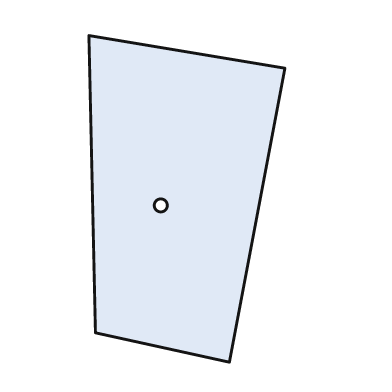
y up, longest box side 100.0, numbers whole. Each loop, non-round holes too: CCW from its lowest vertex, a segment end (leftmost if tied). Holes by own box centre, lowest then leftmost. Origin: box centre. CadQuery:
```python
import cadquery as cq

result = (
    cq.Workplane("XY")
    .moveTo(13.0, -50.0)
    .lineTo(30.0, 40.0)
    .lineTo(-30.0, 50.0)
    .lineTo(-28.0, -41.0)
    .close()
    .moveTo(-8.0, -2.0)
    .circle(2.0)
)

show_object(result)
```